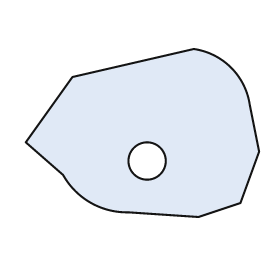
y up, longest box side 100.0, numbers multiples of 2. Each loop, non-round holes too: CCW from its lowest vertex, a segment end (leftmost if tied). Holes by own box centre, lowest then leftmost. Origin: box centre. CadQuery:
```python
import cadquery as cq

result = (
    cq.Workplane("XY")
    .moveTo(24.0, -36.0)
    .lineTo(42.0, -30.0)
    .lineTo(50.0, -8.0)
    .lineTo(46.0, 12.0)
    .threePointArc((38.0, 28.0), (22.0, 36.0))
    .lineTo(-30.0, 24.0)
    .lineTo(-50.0, -4.0)
    .lineTo(-34.0, -18.0)
    .threePointArc((-22.0, -30.0), (-6.0, -34.0))
    .close()
    .moveTo(2.0, -12.0)
    .circle(8.0)
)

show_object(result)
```